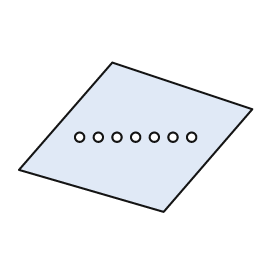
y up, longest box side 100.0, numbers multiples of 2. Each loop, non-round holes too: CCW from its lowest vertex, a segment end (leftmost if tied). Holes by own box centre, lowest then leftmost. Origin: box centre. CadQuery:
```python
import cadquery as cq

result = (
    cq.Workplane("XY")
    .moveTo(12.0, -32.0)
    .lineTo(50.0, 12.0)
    .lineTo(-10.0, 32.0)
    .lineTo(-50.0, -14.0)
    .close()
    .moveTo(-24.0, 0.0)
    .circle(2.0)
    .moveTo(-16.0, 0.0)
    .circle(2.0)
    .moveTo(-8.0, 0.0)
    .circle(2.0)
    .moveTo(0.0, 0.0)
    .circle(2.0)
    .moveTo(8.0, 0.0)
    .circle(2.0)
    .moveTo(16.0, 0.0)
    .circle(2.0)
    .moveTo(24.0, 0.0)
    .circle(2.0)
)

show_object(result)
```